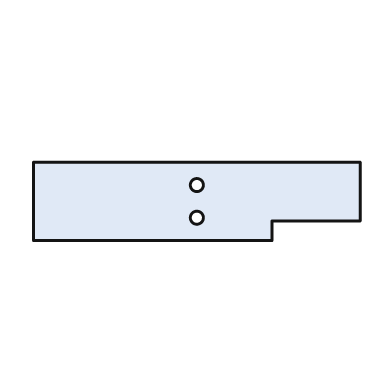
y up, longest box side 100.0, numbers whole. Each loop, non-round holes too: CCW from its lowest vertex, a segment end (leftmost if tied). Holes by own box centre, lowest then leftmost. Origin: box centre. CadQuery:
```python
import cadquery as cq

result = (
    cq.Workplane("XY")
    .moveTo(-50.0, -12.0)
    .lineTo(23.0, -12.0)
    .lineTo(23.0, -6.0)
    .lineTo(50.0, -6.0)
    .lineTo(50.0, 12.0)
    .lineTo(-50.0, 12.0)
    .close()
    .moveTo(0.0, -5.0)
    .circle(2.0)
    .moveTo(0.0, 5.0)
    .circle(2.0)
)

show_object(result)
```